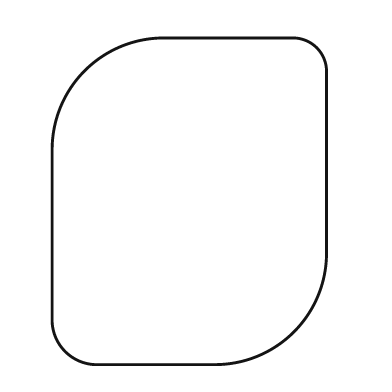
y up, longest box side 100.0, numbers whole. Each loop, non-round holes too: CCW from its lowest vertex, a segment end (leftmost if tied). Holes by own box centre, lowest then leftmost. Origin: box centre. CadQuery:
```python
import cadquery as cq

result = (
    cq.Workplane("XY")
    .moveTo(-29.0, -50.0)
    .lineTo(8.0, -50.0)
    .threePointArc((32.0, -40.0), (42.0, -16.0))
    .lineTo(42.0, 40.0)
    .threePointArc((39.0, 47.0), (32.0, 50.0))
    .lineTo(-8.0, 50.0)
    .threePointArc((-32.0, 40.0), (-42.0, 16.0))
    .lineTo(-42.0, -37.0)
    .threePointArc((-38.0, -46.0), (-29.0, -50.0))
    .close()
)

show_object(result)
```